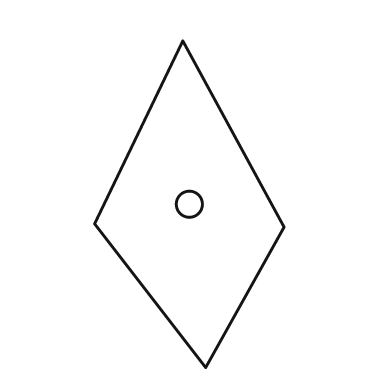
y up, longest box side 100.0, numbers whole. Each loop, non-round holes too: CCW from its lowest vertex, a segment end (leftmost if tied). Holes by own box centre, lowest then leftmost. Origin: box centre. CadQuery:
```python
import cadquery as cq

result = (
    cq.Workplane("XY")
    .moveTo(5.0, -50.0)
    .lineTo(29.0, -7.0)
    .lineTo(-2.0, 50.0)
    .lineTo(-29.0, -6.0)
    .close()
    .moveTo(0.0, 0.0)
    .circle(4.0)
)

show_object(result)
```